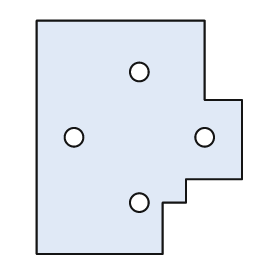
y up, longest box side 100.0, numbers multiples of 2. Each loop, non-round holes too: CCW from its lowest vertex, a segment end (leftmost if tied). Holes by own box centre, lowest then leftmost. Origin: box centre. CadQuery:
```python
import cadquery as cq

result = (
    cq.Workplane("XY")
    .moveTo(-44.0, -50.0)
    .lineTo(10.0, -50.0)
    .lineTo(10.0, -28.0)
    .lineTo(20.0, -28.0)
    .lineTo(20.0, -18.0)
    .lineTo(44.0, -18.0)
    .lineTo(44.0, 16.0)
    .lineTo(28.0, 16.0)
    .lineTo(28.0, 50.0)
    .lineTo(-44.0, 50.0)
    .close()
    .moveTo(0.0, -28.0)
    .circle(4.0)
    .moveTo(-28.0, 0.0)
    .circle(4.0)
    .moveTo(28.0, 0.0)
    .circle(4.0)
    .moveTo(0.0, 28.0)
    .circle(4.0)
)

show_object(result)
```